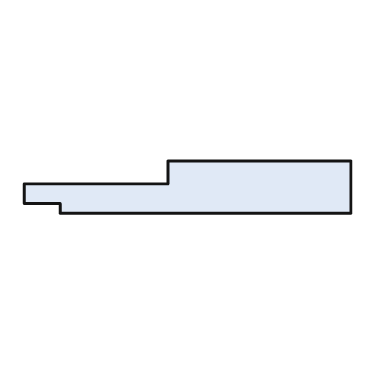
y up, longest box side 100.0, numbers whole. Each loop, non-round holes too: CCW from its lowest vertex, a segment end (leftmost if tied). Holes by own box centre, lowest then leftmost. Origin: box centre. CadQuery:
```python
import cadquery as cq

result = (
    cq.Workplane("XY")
    .moveTo(-39.0, -8.0)
    .lineTo(50.0, -8.0)
    .lineTo(50.0, 8.0)
    .lineTo(-6.0, 8.0)
    .lineTo(-6.0, 1.0)
    .lineTo(-50.0, 1.0)
    .lineTo(-50.0, -5.0)
    .lineTo(-39.0, -5.0)
    .close()
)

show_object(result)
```